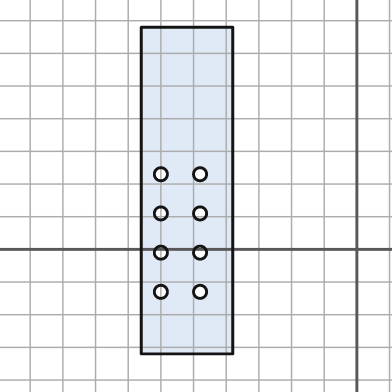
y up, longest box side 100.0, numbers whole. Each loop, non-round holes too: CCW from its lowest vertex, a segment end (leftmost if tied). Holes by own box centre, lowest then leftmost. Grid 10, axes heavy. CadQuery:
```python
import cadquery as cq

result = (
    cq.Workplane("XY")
    .moveTo(-66.0, -32.0)
    .lineTo(-38.0, -32.0)
    .lineTo(-38.0, 68.0)
    .lineTo(-66.0, 68.0)
    .close()
    .moveTo(-60.0, -13.0)
    .circle(2.0)
    .moveTo(-48.0, -13.0)
    .circle(2.0)
    .moveTo(-60.0, -1.0)
    .circle(2.0)
    .moveTo(-48.0, -1.0)
    .circle(2.0)
    .moveTo(-60.0, 11.0)
    .circle(2.0)
    .moveTo(-48.0, 11.0)
    .circle(2.0)
    .moveTo(-60.0, 23.0)
    .circle(2.0)
    .moveTo(-48.0, 23.0)
    .circle(2.0)
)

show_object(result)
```